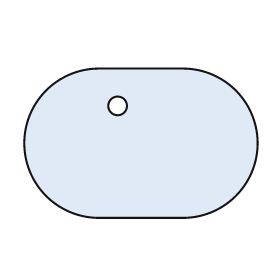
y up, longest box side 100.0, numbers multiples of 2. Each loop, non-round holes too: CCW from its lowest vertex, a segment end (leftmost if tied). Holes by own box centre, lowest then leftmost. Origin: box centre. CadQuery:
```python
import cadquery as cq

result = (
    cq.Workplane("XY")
    .moveTo(-18.0, -32.0)
    .lineTo(18.0, -32.0)
    .threePointArc((50.0, 0.0), (18.0, 32.0))
    .lineTo(-18.0, 32.0)
    .threePointArc((-50.0, 0.0), (-18.0, -32.0))
    .close()
    .moveTo(-10.0, 16.0)
    .circle(4.0)
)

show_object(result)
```